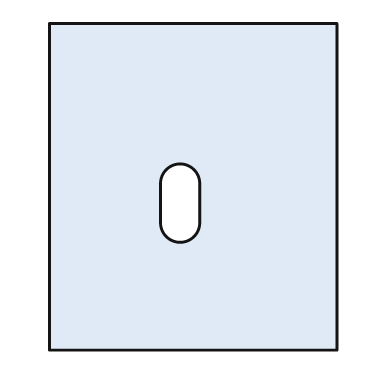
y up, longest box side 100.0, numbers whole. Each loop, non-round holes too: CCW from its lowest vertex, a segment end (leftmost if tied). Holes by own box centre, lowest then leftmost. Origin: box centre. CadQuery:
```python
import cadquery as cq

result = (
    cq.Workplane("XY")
    .moveTo(-44.0, -50.0)
    .lineTo(44.0, -50.0)
    .lineTo(44.0, 50.0)
    .lineTo(-44.0, 50.0)
    .close()
    .moveTo(-10.0, -11.0)
    .threePointArc((-4.0, -17.0), (2.0, -11.0))
    .lineTo(2.0, 1.0)
    .threePointArc((-4.0, 7.0), (-10.0, 1.0))
    .close()
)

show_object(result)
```